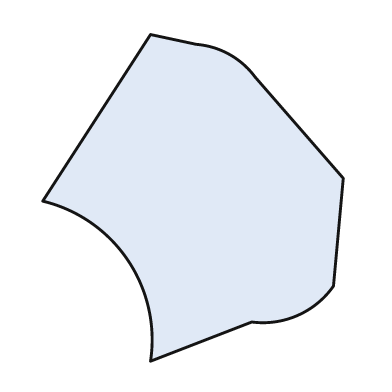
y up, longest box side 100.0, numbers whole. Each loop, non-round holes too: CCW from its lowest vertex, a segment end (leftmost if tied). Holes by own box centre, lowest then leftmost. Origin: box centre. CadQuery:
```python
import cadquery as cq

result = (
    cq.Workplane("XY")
    .moveTo(-13.0, -50.0)
    .lineTo(18.0, -38.0)
    .threePointArc((32.0, -36.0), (43.0, -27.0))
    .lineTo(46.0, 6.0)
    .lineTo(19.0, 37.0)
    .threePointArc((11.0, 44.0), (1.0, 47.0))
    .lineTo(-13.0, 50.0)
    .lineTo(-46.0, -1.0)
    .threePointArc((-20.0, -19.0), (-13.0, -50.0))
    .close()
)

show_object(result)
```